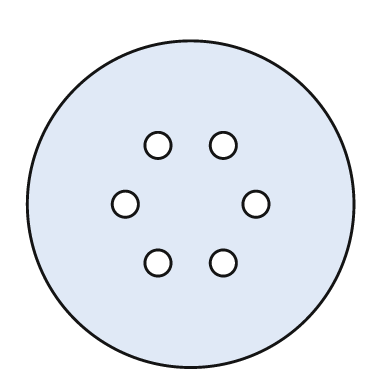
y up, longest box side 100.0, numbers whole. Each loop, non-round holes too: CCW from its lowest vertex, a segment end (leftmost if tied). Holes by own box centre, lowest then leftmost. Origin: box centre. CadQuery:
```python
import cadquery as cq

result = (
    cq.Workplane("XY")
    .moveTo(0.0, 0.0)
    .circle(50.0)
    .moveTo(-10.0, -18.0)
    .circle(4.0)
    .moveTo(10.0, -18.0)
    .circle(4.0)
    .moveTo(-20.0, 0.0)
    .circle(4.0)
    .moveTo(20.0, 0.0)
    .circle(4.0)
    .moveTo(-10.0, 18.0)
    .circle(4.0)
    .moveTo(10.0, 18.0)
    .circle(4.0)
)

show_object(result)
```